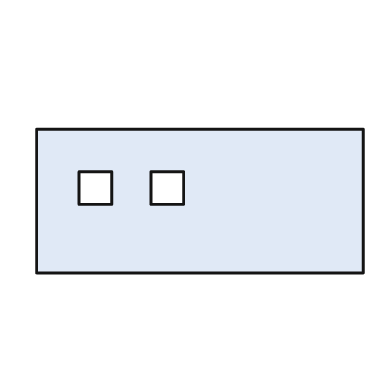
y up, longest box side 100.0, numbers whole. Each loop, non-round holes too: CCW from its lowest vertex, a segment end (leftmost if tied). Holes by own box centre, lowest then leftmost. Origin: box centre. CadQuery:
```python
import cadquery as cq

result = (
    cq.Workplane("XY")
    .moveTo(-50.0, -22.0)
    .lineTo(50.0, -22.0)
    .lineTo(50.0, 22.0)
    .lineTo(-50.0, 22.0)
    .close()
    .moveTo(-37.0, -1.0)
    .lineTo(-27.0, -1.0)
    .lineTo(-27.0, 9.0)
    .lineTo(-37.0, 9.0)
    .close()
    .moveTo(-15.0, -1.0)
    .lineTo(-5.0, -1.0)
    .lineTo(-5.0, 9.0)
    .lineTo(-15.0, 9.0)
    .close()
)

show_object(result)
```